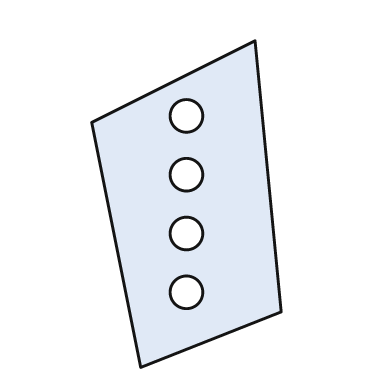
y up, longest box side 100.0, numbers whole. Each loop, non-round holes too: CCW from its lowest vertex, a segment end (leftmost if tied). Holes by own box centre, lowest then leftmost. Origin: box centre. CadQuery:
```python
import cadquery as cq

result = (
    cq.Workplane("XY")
    .moveTo(-14.0, -50.0)
    .lineTo(29.0, -33.0)
    .lineTo(21.0, 50.0)
    .lineTo(-29.0, 25.0)
    .close()
    .moveTo(0.0, -27.0)
    .circle(5.0)
    .moveTo(0.0, -9.0)
    .circle(5.0)
    .moveTo(0.0, 9.0)
    .circle(5.0)
    .moveTo(0.0, 27.0)
    .circle(5.0)
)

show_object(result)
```